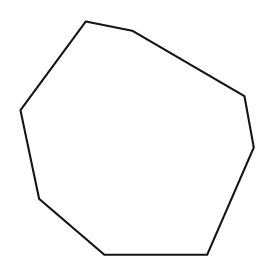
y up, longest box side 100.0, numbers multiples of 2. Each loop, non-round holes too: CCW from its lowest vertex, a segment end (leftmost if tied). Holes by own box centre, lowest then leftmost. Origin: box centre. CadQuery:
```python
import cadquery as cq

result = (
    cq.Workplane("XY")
    .moveTo(-14.0, -50.0)
    .lineTo(30.0, -50.0)
    .lineTo(50.0, -4.0)
    .lineTo(46.0, 18.0)
    .lineTo(-2.0, 46.0)
    .lineTo(-22.0, 50.0)
    .lineTo(-50.0, 12.0)
    .lineTo(-42.0, -26.0)
    .close()
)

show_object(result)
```